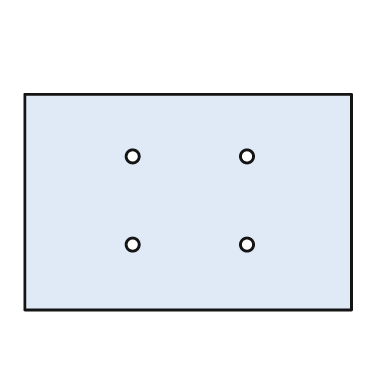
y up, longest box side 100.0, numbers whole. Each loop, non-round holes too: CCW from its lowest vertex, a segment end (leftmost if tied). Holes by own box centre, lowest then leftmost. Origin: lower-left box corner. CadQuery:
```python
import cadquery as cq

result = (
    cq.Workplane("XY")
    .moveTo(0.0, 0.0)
    .lineTo(100.0, 0.0)
    .lineTo(100.0, 66.0)
    .lineTo(0.0, 66.0)
    .close()
    .moveTo(33.0, 20.0)
    .circle(2.0)
    .moveTo(68.0, 20.0)
    .circle(2.0)
    .moveTo(33.0, 47.0)
    .circle(2.0)
    .moveTo(68.0, 47.0)
    .circle(2.0)
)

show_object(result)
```